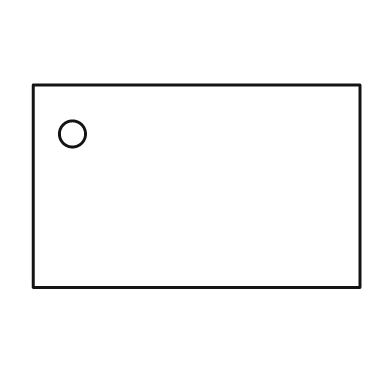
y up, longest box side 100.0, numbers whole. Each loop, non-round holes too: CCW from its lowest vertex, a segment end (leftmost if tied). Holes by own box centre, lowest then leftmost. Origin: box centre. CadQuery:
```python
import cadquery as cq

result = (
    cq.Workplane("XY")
    .moveTo(-50.0, -31.0)
    .lineTo(50.0, -31.0)
    .lineTo(50.0, 31.0)
    .lineTo(-50.0, 31.0)
    .close()
    .moveTo(-38.0, 16.0)
    .circle(4.0)
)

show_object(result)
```